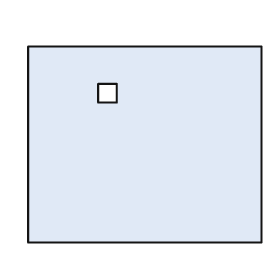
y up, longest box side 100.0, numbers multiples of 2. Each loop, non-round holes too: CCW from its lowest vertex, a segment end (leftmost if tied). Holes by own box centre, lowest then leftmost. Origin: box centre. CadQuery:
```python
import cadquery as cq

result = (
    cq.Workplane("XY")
    .moveTo(-50.0, -42.0)
    .lineTo(50.0, -42.0)
    .lineTo(50.0, 42.0)
    .lineTo(-50.0, 42.0)
    .close()
    .moveTo(-20.0, 18.0)
    .lineTo(-12.0, 18.0)
    .lineTo(-12.0, 26.0)
    .lineTo(-20.0, 26.0)
    .close()
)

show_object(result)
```